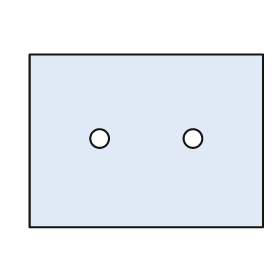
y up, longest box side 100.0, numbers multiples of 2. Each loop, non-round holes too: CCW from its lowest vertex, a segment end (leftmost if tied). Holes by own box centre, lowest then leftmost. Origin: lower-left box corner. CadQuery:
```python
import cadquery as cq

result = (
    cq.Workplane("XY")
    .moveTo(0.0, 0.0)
    .lineTo(100.0, 0.0)
    .lineTo(100.0, 74.0)
    .lineTo(0.0, 74.0)
    .close()
    .moveTo(30.0, 38.0)
    .circle(4.0)
    .moveTo(70.0, 38.0)
    .circle(4.0)
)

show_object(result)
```